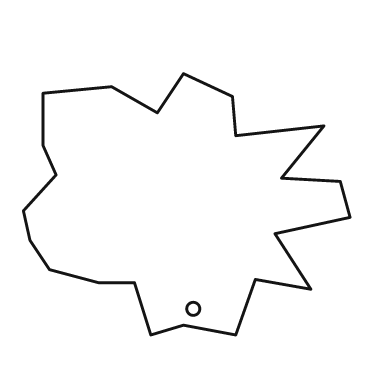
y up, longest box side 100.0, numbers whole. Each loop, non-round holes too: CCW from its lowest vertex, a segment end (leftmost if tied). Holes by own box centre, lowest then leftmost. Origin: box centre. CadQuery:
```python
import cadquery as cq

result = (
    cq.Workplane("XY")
    .moveTo(-11.0, -40.0)
    .lineTo(-1.0, -37.0)
    .lineTo(15.0, -40.0)
    .lineTo(21.0, -23.0)
    .lineTo(38.0, -26.0)
    .lineTo(27.0, -9.0)
    .lineTo(50.0, -4.0)
    .lineTo(47.0, 7.0)
    .lineTo(29.0, 8.0)
    .lineTo(42.0, 24.0)
    .lineTo(15.0, 21.0)
    .lineTo(14.0, 33.0)
    .lineTo(-1.0, 40.0)
    .lineTo(-9.0, 28.0)
    .lineTo(-23.0, 36.0)
    .lineTo(-44.0, 34.0)
    .lineTo(-44.0, 18.0)
    .lineTo(-40.0, 9.0)
    .lineTo(-50.0, -2.0)
    .lineTo(-48.0, -11.0)
    .lineTo(-42.0, -20.0)
    .lineTo(-27.0, -24.0)
    .lineTo(-16.0, -24.0)
    .close()
    .moveTo(2.0, -32.0)
    .circle(2.0)
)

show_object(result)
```